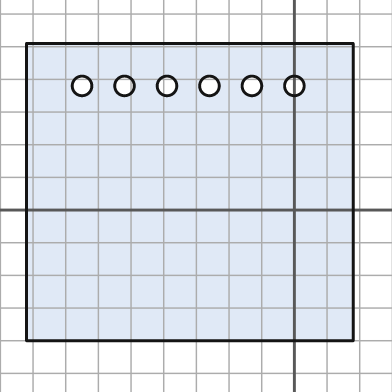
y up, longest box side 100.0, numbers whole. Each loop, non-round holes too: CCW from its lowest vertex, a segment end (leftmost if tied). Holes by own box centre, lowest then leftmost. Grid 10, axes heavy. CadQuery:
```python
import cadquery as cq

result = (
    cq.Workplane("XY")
    .moveTo(-82.0, -40.0)
    .lineTo(18.0, -40.0)
    .lineTo(18.0, 51.0)
    .lineTo(-82.0, 51.0)
    .close()
    .moveTo(-65.0, 38.0)
    .circle(3.0)
    .moveTo(-52.0, 38.0)
    .circle(3.0)
    .moveTo(-39.0, 38.0)
    .circle(3.0)
    .moveTo(-26.0, 38.0)
    .circle(3.0)
    .moveTo(-13.0, 38.0)
    .circle(3.0)
    .moveTo(0.0, 38.0)
    .circle(3.0)
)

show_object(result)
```